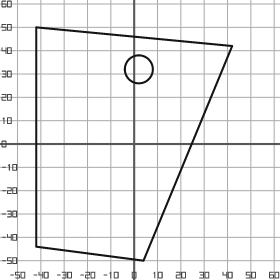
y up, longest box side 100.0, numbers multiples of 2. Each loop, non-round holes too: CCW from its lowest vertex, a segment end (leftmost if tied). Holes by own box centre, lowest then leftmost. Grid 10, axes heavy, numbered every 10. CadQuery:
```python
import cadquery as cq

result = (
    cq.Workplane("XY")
    .moveTo(4.0, -50.0)
    .lineTo(42.0, 42.0)
    .lineTo(-42.0, 50.0)
    .lineTo(-42.0, -44.0)
    .close()
    .moveTo(2.0, 32.0)
    .circle(6.0)
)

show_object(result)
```